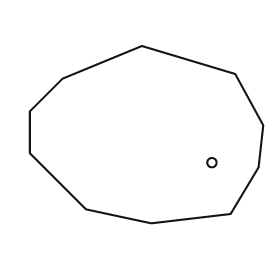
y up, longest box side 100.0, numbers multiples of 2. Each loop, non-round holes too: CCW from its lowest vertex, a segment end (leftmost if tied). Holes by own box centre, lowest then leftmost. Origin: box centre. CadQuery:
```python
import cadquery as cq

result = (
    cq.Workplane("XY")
    .moveTo(2.0, -38.0)
    .lineTo(36.0, -34.0)
    .lineTo(48.0, -14.0)
    .lineTo(50.0, 4.0)
    .lineTo(38.0, 26.0)
    .lineTo(-2.0, 38.0)
    .lineTo(-36.0, 24.0)
    .lineTo(-50.0, 10.0)
    .lineTo(-50.0, -8.0)
    .lineTo(-26.0, -32.0)
    .close()
    .moveTo(28.0, -12.0)
    .circle(2.0)
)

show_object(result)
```